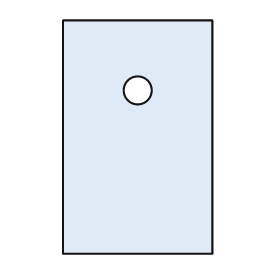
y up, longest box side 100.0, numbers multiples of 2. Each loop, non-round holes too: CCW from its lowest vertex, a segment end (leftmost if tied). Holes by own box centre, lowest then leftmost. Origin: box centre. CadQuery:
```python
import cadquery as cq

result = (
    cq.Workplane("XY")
    .moveTo(-32.0, -50.0)
    .lineTo(32.0, -50.0)
    .lineTo(32.0, 50.0)
    .lineTo(-32.0, 50.0)
    .close()
    .moveTo(0.0, 20.0)
    .circle(6.0)
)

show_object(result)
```